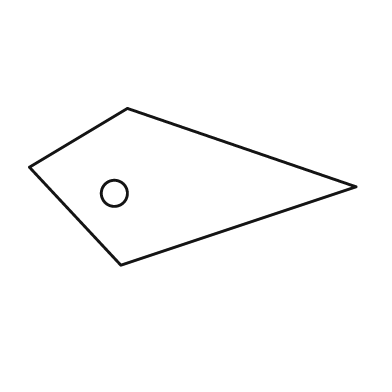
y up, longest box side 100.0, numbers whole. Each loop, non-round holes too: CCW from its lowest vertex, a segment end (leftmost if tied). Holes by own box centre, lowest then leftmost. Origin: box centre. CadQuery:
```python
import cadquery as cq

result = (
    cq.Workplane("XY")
    .moveTo(-22.0, -24.0)
    .lineTo(50.0, 0.0)
    .lineTo(-20.0, 24.0)
    .lineTo(-50.0, 6.0)
    .close()
    .moveTo(-24.0, -2.0)
    .circle(4.0)
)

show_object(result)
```